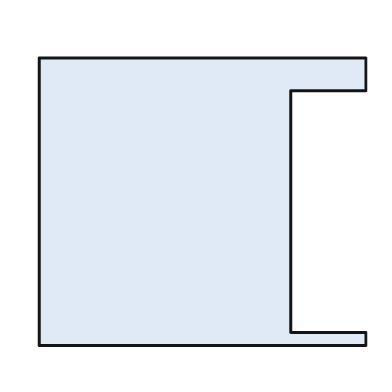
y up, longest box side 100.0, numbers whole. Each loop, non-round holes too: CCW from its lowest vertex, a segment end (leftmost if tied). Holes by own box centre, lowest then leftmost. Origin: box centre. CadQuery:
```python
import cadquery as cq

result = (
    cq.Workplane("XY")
    .moveTo(-50.0, -44.0)
    .lineTo(50.0, -44.0)
    .lineTo(50.0, -40.0)
    .lineTo(27.0, -40.0)
    .lineTo(27.0, 34.0)
    .lineTo(50.0, 34.0)
    .lineTo(50.0, 44.0)
    .lineTo(-50.0, 44.0)
    .close()
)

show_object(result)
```